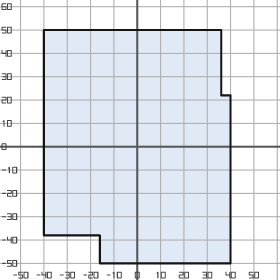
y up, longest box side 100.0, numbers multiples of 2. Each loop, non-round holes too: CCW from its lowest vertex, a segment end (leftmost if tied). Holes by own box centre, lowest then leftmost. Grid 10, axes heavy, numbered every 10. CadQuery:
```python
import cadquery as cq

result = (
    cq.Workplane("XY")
    .moveTo(-16.0, -50.0)
    .lineTo(40.0, -50.0)
    .lineTo(40.0, 22.0)
    .lineTo(36.0, 22.0)
    .lineTo(36.0, 50.0)
    .lineTo(-40.0, 50.0)
    .lineTo(-40.0, -38.0)
    .lineTo(-16.0, -38.0)
    .close()
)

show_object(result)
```